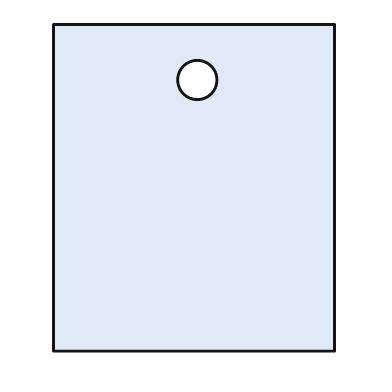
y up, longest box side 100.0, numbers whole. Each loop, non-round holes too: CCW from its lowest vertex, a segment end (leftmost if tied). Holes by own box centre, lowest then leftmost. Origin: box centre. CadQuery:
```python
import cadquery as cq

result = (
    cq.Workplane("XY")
    .moveTo(-43.0, -50.0)
    .lineTo(43.0, -50.0)
    .lineTo(43.0, 50.0)
    .lineTo(-43.0, 50.0)
    .close()
    .moveTo(1.0, 33.0)
    .circle(6.0)
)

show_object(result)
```